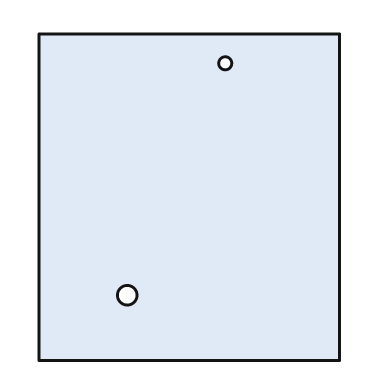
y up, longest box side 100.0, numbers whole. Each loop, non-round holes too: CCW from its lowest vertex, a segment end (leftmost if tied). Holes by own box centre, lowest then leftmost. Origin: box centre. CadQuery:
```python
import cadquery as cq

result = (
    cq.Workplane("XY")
    .moveTo(-46.0, -50.0)
    .lineTo(46.0, -50.0)
    .lineTo(46.0, 50.0)
    .lineTo(-46.0, 50.0)
    .close()
    .moveTo(-19.0, -30.0)
    .circle(3.0)
    .moveTo(11.0, 41.0)
    .circle(2.0)
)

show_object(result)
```